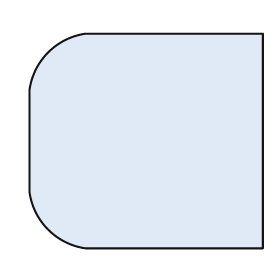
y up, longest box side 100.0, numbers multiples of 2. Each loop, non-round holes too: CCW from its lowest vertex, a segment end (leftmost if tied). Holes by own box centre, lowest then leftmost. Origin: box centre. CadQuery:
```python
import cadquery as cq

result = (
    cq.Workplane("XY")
    .moveTo(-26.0, -46.0)
    .lineTo(50.0, -46.0)
    .lineTo(50.0, 46.0)
    .lineTo(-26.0, 46.0)
    .threePointArc((-42.0, 38.0), (-50.0, 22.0))
    .lineTo(-50.0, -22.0)
    .threePointArc((-42.0, -38.0), (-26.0, -46.0))
    .close()
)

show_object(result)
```